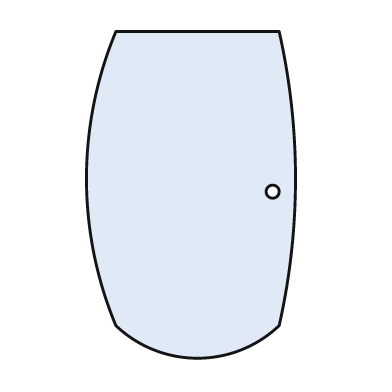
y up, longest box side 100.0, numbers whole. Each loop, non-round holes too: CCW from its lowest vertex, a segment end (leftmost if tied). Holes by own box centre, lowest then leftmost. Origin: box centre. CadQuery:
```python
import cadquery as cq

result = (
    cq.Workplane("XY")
    .moveTo(-23.0, -40.0)
    .threePointArc((2.0, -50.0), (27.0, -40.0))
    .threePointArc((32.0, 5.0), (27.0, 50.0))
    .lineTo(-23.0, 50.0)
    .threePointArc((-32.0, 5.0), (-23.0, -40.0))
    .close()
    .moveTo(25.0, 1.0)
    .circle(2.0)
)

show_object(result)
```